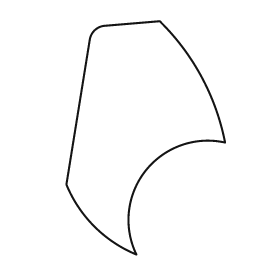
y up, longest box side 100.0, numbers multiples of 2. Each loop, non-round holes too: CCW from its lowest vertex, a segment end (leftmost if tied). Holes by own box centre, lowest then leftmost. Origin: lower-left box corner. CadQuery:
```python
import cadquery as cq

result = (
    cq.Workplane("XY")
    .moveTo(30.0, 0.0)
    .threePointArc((34.0, 36.0), (68.0, 48.0))
    .threePointArc((58.0, 76.0), (40.0, 100.0))
    .lineTo(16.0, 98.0)
    .threePointArc((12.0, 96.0), (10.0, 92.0))
    .lineTo(0.0, 30.0)
    .threePointArc((12.0, 12.0), (30.0, 0.0))
    .close()
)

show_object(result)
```